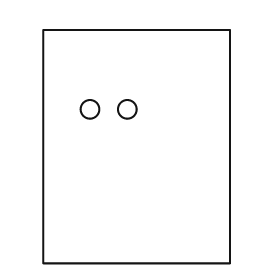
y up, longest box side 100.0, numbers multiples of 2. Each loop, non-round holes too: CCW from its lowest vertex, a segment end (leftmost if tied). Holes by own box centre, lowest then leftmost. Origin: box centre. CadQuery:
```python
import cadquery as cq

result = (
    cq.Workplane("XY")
    .moveTo(-40.0, -50.0)
    .lineTo(40.0, -50.0)
    .lineTo(40.0, 50.0)
    .lineTo(-40.0, 50.0)
    .close()
    .moveTo(-20.0, 16.0)
    .circle(4.0)
    .moveTo(-4.0, 16.0)
    .circle(4.0)
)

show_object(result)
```